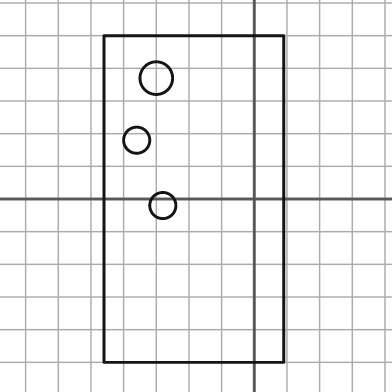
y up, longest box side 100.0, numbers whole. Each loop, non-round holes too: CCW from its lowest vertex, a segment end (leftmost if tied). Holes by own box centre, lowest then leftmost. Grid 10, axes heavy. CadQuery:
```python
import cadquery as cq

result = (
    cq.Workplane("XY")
    .moveTo(-46.0, -50.0)
    .lineTo(9.0, -50.0)
    .lineTo(9.0, 50.0)
    .lineTo(-46.0, 50.0)
    .close()
    .moveTo(-28.0, -2.0)
    .circle(4.0)
    .moveTo(-36.0, 18.0)
    .circle(4.0)
    .moveTo(-30.0, 37.0)
    .circle(5.0)
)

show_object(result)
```